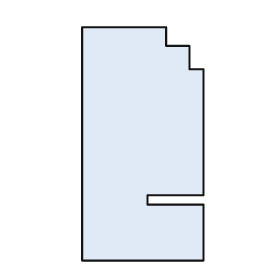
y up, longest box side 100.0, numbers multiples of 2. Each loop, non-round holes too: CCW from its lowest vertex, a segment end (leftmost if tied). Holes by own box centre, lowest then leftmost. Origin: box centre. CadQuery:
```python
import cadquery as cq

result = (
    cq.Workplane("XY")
    .moveTo(-26.0, -50.0)
    .lineTo(26.0, -50.0)
    .lineTo(26.0, -26.0)
    .lineTo(2.0, -26.0)
    .lineTo(2.0, -22.0)
    .lineTo(26.0, -22.0)
    .lineTo(26.0, 32.0)
    .lineTo(20.0, 32.0)
    .lineTo(20.0, 42.0)
    .lineTo(10.0, 42.0)
    .lineTo(10.0, 50.0)
    .lineTo(-26.0, 50.0)
    .close()
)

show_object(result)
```